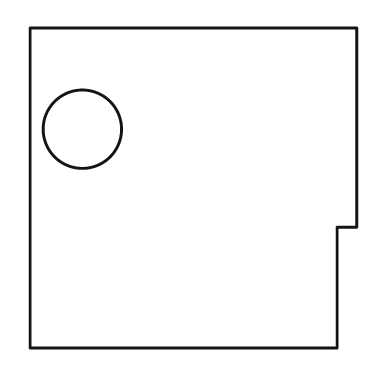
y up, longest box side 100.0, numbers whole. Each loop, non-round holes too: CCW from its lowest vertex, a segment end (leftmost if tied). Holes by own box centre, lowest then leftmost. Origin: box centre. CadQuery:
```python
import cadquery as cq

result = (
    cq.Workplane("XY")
    .moveTo(-50.0, -49.0)
    .lineTo(44.0, -49.0)
    .lineTo(44.0, -12.0)
    .lineTo(50.0, -12.0)
    .lineTo(50.0, 49.0)
    .lineTo(-50.0, 49.0)
    .close()
    .moveTo(-34.0, 18.0)
    .circle(12.0)
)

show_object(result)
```